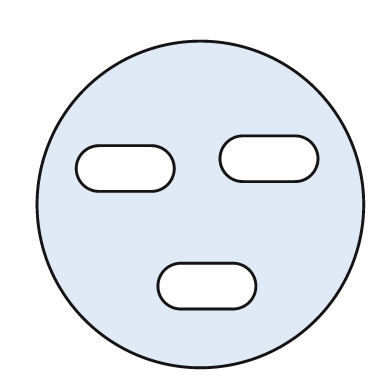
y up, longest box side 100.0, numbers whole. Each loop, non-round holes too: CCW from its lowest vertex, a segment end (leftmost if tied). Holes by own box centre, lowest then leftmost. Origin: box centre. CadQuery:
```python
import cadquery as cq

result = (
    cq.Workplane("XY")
    .moveTo(0.0, 0.0)
    .circle(50.0)
    .moveTo(-6.0, -32.0)
    .lineTo(10.0, -32.0)
    .threePointArc((17.0, -25.0), (10.0, -18.0))
    .lineTo(-6.0, -18.0)
    .threePointArc((-13.0, -25.0), (-6.0, -32.0))
    .close()
    .moveTo(-31.0, 4.0)
    .lineTo(-15.0, 4.0)
    .threePointArc((-8.0, 11.0), (-15.0, 18.0))
    .lineTo(-31.0, 18.0)
    .threePointArc((-38.0, 11.0), (-31.0, 4.0))
    .close()
    .moveTo(13.0, 7.0)
    .lineTo(29.0, 7.0)
    .threePointArc((36.0, 14.0), (29.0, 21.0))
    .lineTo(13.0, 21.0)
    .threePointArc((6.0, 14.0), (13.0, 7.0))
    .close()
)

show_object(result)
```